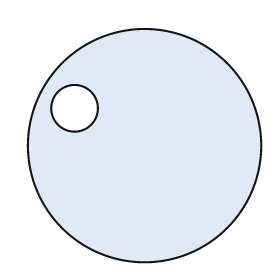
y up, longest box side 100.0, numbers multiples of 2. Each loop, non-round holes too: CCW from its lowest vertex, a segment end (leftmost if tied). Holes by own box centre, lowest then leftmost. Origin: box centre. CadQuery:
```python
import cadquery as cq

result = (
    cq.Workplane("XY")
    .moveTo(0.0, 0.0)
    .circle(50.0)
    .moveTo(-30.0, 16.0)
    .circle(10.0)
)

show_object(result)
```